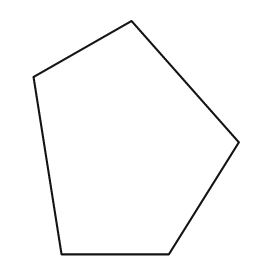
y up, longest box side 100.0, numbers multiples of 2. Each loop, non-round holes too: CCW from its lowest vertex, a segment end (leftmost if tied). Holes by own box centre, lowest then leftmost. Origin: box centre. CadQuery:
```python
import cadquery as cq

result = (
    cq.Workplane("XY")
    .moveTo(-32.0, -50.0)
    .lineTo(14.0, -50.0)
    .lineTo(44.0, -2.0)
    .lineTo(-2.0, 50.0)
    .lineTo(-44.0, 26.0)
    .close()
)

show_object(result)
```